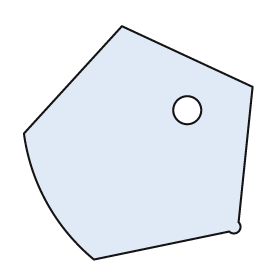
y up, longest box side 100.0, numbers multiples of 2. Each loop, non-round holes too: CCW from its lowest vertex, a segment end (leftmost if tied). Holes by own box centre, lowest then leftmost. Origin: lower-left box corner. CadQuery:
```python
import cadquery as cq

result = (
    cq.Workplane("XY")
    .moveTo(30.0, 0.0)
    .lineTo(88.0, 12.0)
    .threePointArc((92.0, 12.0), (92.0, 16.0))
    .lineTo(98.0, 74.0)
    .lineTo(42.0, 100.0)
    .lineTo(0.0, 54.0)
    .threePointArc((10.0, 24.0), (30.0, 0.0))
    .close()
    .moveTo(70.0, 64.0)
    .circle(6.0)
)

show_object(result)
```